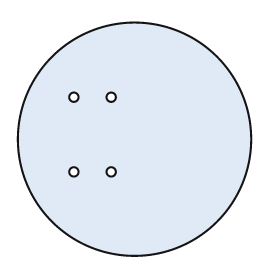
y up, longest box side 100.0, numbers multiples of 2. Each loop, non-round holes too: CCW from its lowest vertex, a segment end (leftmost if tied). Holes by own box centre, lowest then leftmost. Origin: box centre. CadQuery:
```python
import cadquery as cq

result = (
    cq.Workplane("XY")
    .moveTo(0.0, 0.0)
    .circle(50.0)
    .moveTo(-26.0, -14.0)
    .circle(2.0)
    .moveTo(-10.0, -14.0)
    .circle(2.0)
    .moveTo(-26.0, 18.0)
    .circle(2.0)
    .moveTo(-10.0, 18.0)
    .circle(2.0)
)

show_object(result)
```